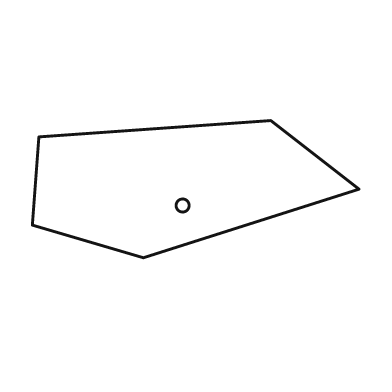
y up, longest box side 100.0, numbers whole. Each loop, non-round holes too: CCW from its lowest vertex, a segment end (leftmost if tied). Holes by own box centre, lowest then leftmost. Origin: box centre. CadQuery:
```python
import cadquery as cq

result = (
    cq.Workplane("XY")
    .moveTo(-16.0, -21.0)
    .lineTo(50.0, 0.0)
    .lineTo(23.0, 21.0)
    .lineTo(-48.0, 16.0)
    .lineTo(-50.0, -11.0)
    .close()
    .moveTo(-4.0, -5.0)
    .circle(2.0)
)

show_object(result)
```